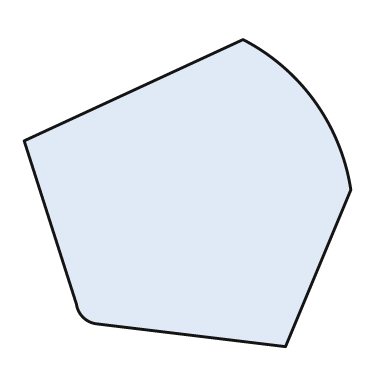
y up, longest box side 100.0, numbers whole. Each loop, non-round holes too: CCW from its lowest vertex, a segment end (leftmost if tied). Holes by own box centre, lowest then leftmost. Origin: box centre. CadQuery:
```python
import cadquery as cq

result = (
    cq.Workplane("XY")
    .moveTo(30.0, -47.0)
    .lineTo(50.0, 1.0)
    .threePointArc((39.0, 28.0), (17.0, 47.0))
    .lineTo(-50.0, 16.0)
    .lineTo(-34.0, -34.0)
    .threePointArc((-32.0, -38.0), (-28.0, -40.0))
    .close()
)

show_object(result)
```